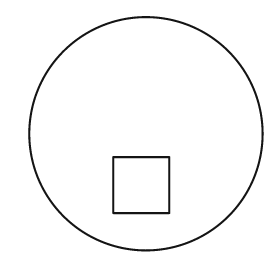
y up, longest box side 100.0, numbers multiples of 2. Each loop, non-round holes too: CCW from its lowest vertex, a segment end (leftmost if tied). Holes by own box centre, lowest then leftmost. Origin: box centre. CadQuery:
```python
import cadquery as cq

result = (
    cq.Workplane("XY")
    .moveTo(0.0, 0.0)
    .circle(50.0)
    .moveTo(-14.0, -34.0)
    .lineTo(10.0, -34.0)
    .lineTo(10.0, -10.0)
    .lineTo(-14.0, -10.0)
    .close()
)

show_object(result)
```